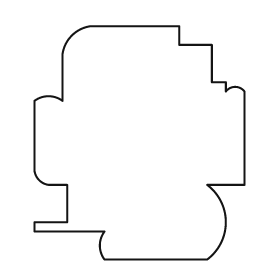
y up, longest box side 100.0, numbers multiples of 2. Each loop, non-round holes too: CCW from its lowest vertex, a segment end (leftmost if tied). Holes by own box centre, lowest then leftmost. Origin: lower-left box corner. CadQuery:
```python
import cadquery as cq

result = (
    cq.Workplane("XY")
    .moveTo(30.0, 0.0)
    .lineTo(74.0, 0.0)
    .threePointArc((82.0, 16.0), (74.0, 32.0))
    .lineTo(90.0, 32.0)
    .lineTo(90.0, 72.0)
    .threePointArc((86.0, 74.0), (82.0, 72.0))
    .lineTo(82.0, 76.0)
    .lineTo(76.0, 76.0)
    .lineTo(76.0, 92.0)
    .lineTo(62.0, 92.0)
    .lineTo(62.0, 100.0)
    .lineTo(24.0, 100.0)
    .threePointArc((16.0, 96.0), (12.0, 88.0))
    .lineTo(12.0, 68.0)
    .threePointArc((6.0, 70.0), (0.0, 68.0))
    .lineTo(0.0, 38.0)
    .threePointArc((2.0, 34.0), (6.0, 32.0))
    .lineTo(14.0, 32.0)
    .lineTo(14.0, 16.0)
    .lineTo(0.0, 16.0)
    .lineTo(0.0, 12.0)
    .lineTo(30.0, 12.0)
    .threePointArc((28.0, 6.0), (30.0, 0.0))
    .close()
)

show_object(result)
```